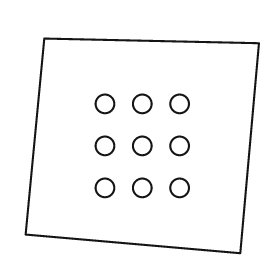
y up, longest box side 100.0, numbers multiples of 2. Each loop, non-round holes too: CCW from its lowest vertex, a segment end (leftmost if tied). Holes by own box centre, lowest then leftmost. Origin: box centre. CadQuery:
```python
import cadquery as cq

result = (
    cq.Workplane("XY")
    .moveTo(42.0, -46.0)
    .lineTo(50.0, 44.0)
    .lineTo(-42.0, 46.0)
    .lineTo(-50.0, -38.0)
    .close()
    .moveTo(-16.0, -18.0)
    .circle(4.0)
    .moveTo(0.0, -18.0)
    .circle(4.0)
    .moveTo(16.0, -18.0)
    .circle(4.0)
    .moveTo(-16.0, 0.0)
    .circle(4.0)
    .moveTo(0.0, 0.0)
    .circle(4.0)
    .moveTo(16.0, 0.0)
    .circle(4.0)
    .moveTo(-16.0, 18.0)
    .circle(4.0)
    .moveTo(0.0, 18.0)
    .circle(4.0)
    .moveTo(16.0, 18.0)
    .circle(4.0)
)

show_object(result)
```